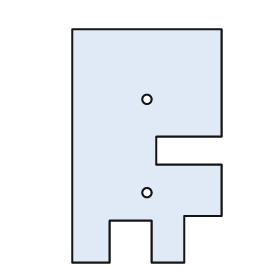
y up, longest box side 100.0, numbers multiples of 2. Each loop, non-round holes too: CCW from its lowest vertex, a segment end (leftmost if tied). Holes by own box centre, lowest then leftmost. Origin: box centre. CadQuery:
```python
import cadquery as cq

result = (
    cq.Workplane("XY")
    .moveTo(-32.0, -50.0)
    .lineTo(-16.0, -50.0)
    .lineTo(-16.0, -32.0)
    .lineTo(2.0, -32.0)
    .lineTo(2.0, -50.0)
    .lineTo(16.0, -50.0)
    .lineTo(16.0, -30.0)
    .lineTo(32.0, -30.0)
    .lineTo(32.0, -8.0)
    .lineTo(4.0, -8.0)
    .lineTo(4.0, 4.0)
    .lineTo(32.0, 4.0)
    .lineTo(32.0, 50.0)
    .lineTo(-32.0, 50.0)
    .close()
    .moveTo(0.0, -20.0)
    .circle(2.0)
    .moveTo(0.0, 20.0)
    .circle(2.0)
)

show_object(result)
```